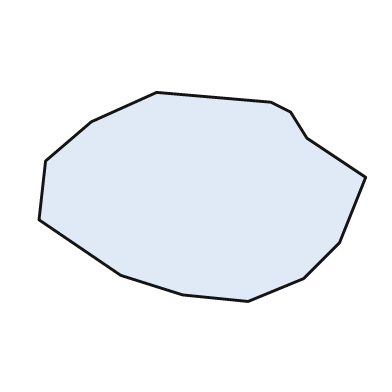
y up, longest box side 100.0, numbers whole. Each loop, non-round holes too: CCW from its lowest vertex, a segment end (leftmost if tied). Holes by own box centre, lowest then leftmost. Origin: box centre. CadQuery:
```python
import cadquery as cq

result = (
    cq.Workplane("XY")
    .moveTo(14.0, -32.0)
    .lineTo(31.0, -25.0)
    .lineTo(42.0, -14.0)
    .lineTo(50.0, 6.0)
    .lineTo(32.0, 18.0)
    .lineTo(27.0, 26.0)
    .lineTo(21.0, 29.0)
    .lineTo(-14.0, 32.0)
    .lineTo(-34.0, 23.0)
    .lineTo(-48.0, 11.0)
    .lineTo(-50.0, -7.0)
    .lineTo(-25.0, -24.0)
    .lineTo(-6.0, -30.0)
    .close()
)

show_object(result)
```